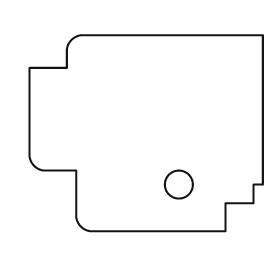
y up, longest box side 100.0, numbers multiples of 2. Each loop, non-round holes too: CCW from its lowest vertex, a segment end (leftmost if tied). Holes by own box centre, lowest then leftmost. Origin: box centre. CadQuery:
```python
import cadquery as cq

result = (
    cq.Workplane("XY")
    .moveTo(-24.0, -42.0)
    .lineTo(34.0, -42.0)
    .lineTo(34.0, -30.0)
    .lineTo(46.0, -30.0)
    .lineTo(46.0, -22.0)
    .lineTo(50.0, -22.0)
    .lineTo(50.0, 42.0)
    .lineTo(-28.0, 42.0)
    .threePointArc((-32.0, 40.0), (-34.0, 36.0))
    .lineTo(-34.0, 28.0)
    .lineTo(-50.0, 28.0)
    .lineTo(-50.0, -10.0)
    .threePointArc((-48.0, -14.0), (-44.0, -16.0))
    .lineTo(-30.0, -16.0)
    .lineTo(-30.0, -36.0)
    .threePointArc((-28.0, -40.0), (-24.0, -42.0))
    .close()
    .moveTo(14.0, -22.0)
    .circle(6.0)
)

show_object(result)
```